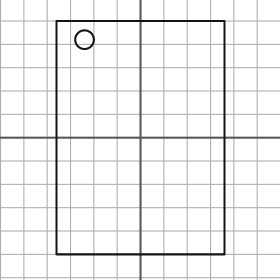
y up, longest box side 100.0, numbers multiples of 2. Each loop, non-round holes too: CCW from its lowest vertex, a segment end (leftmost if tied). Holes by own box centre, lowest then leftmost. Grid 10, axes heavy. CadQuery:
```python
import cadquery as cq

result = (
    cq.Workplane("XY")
    .moveTo(-36.0, -50.0)
    .lineTo(36.0, -50.0)
    .lineTo(36.0, 50.0)
    .lineTo(-36.0, 50.0)
    .close()
    .moveTo(-24.0, 42.0)
    .circle(4.0)
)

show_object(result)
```